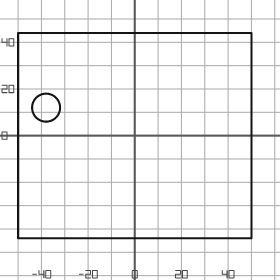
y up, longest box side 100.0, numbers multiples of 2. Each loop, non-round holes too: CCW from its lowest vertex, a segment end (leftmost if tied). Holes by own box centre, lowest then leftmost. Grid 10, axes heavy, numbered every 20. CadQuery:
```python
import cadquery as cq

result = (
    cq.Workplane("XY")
    .moveTo(-50.0, -44.0)
    .lineTo(50.0, -44.0)
    .lineTo(50.0, 44.0)
    .lineTo(-50.0, 44.0)
    .close()
    .moveTo(-38.0, 12.0)
    .circle(6.0)
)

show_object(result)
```